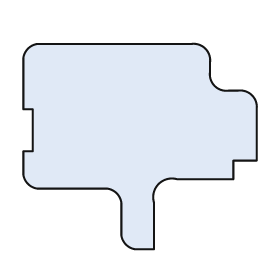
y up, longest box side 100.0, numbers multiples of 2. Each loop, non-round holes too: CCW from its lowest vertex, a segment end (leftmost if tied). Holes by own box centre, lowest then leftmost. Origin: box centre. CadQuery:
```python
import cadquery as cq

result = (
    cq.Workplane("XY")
    .moveTo(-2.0, -44.0)
    .lineTo(6.0, -44.0)
    .lineTo(6.0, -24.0)
    .threePointArc((8.0, -16.0), (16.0, -14.0))
    .lineTo(40.0, -14.0)
    .lineTo(40.0, -6.0)
    .lineTo(50.0, -6.0)
    .lineTo(50.0, 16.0)
    .threePointArc((48.0, 22.0), (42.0, 24.0))
    .lineTo(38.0, 24.0)
    .threePointArc((32.0, 26.0), (30.0, 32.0))
    .lineTo(30.0, 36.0)
    .threePointArc((28.0, 42.0), (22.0, 44.0))
    .lineTo(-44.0, 44.0)
    .threePointArc((-48.0, 42.0), (-50.0, 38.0))
    .lineTo(-50.0, 16.0)
    .lineTo(-46.0, 16.0)
    .lineTo(-46.0, -2.0)
    .lineTo(-50.0, -2.0)
    .lineTo(-50.0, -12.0)
    .threePointArc((-48.0, -16.0), (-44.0, -18.0))
    .lineTo(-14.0, -18.0)
    .threePointArc((-10.0, -20.0), (-8.0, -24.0))
    .lineTo(-8.0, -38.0)
    .threePointArc((-6.0, -42.0), (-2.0, -44.0))
    .close()
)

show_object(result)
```